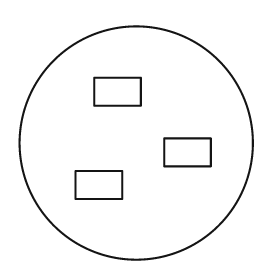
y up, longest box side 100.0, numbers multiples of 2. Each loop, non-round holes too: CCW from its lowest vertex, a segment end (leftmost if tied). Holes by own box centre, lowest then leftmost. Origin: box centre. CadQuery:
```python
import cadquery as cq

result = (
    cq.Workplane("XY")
    .moveTo(0.0, 0.0)
    .circle(50.0)
    .moveTo(-26.0, -24.0)
    .lineTo(-6.0, -24.0)
    .lineTo(-6.0, -12.0)
    .lineTo(-26.0, -12.0)
    .close()
    .moveTo(12.0, -10.0)
    .lineTo(32.0, -10.0)
    .lineTo(32.0, 2.0)
    .lineTo(12.0, 2.0)
    .close()
    .moveTo(-18.0, 16.0)
    .lineTo(2.0, 16.0)
    .lineTo(2.0, 28.0)
    .lineTo(-18.0, 28.0)
    .close()
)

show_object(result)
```